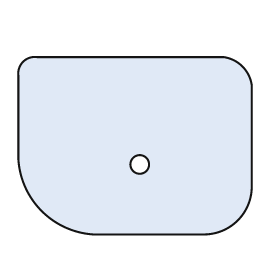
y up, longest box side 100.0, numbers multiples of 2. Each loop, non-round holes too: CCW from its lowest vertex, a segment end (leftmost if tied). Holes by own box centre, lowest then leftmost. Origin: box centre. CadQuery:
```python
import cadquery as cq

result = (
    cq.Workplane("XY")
    .moveTo(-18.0, -38.0)
    .lineTo(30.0, -38.0)
    .threePointArc((44.0, -32.0), (50.0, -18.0))
    .lineTo(50.0, 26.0)
    .threePointArc((46.0, 34.0), (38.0, 38.0))
    .lineTo(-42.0, 38.0)
    .threePointArc((-48.0, 36.0), (-50.0, 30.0))
    .lineTo(-50.0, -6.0)
    .threePointArc((-40.0, -28.0), (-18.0, -38.0))
    .close()
    .moveTo(2.0, -8.0)
    .circle(4.0)
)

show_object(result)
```